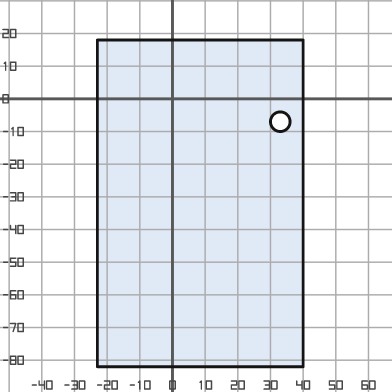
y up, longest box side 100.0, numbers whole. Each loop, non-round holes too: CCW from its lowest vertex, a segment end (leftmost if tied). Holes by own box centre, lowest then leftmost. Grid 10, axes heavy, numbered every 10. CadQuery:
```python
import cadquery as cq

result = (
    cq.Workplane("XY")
    .moveTo(-23.0, -82.0)
    .lineTo(40.0, -82.0)
    .lineTo(40.0, 18.0)
    .lineTo(-23.0, 18.0)
    .close()
    .moveTo(33.0, -7.0)
    .circle(3.0)
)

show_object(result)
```